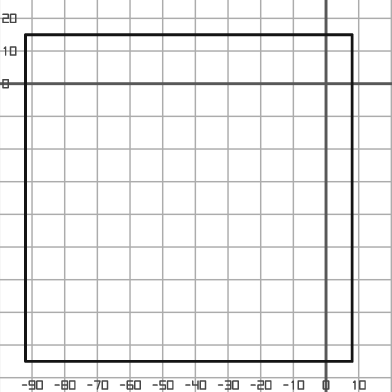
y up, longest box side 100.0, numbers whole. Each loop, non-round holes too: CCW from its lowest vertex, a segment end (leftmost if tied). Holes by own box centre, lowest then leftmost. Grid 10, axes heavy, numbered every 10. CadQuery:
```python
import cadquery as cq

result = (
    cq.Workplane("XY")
    .moveTo(-92.0, -85.0)
    .lineTo(8.0, -85.0)
    .lineTo(8.0, 15.0)
    .lineTo(-92.0, 15.0)
    .close()
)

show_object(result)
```